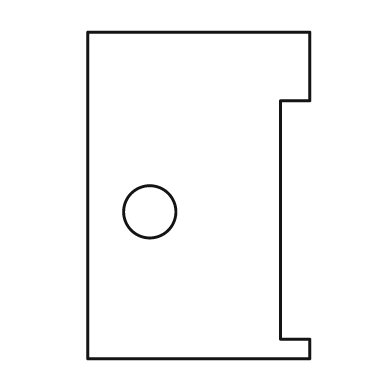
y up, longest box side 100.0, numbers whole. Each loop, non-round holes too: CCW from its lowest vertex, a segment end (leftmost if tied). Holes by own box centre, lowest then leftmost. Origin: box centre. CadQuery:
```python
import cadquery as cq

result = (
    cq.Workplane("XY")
    .moveTo(-34.0, -50.0)
    .lineTo(34.0, -50.0)
    .lineTo(34.0, -44.0)
    .lineTo(25.0, -44.0)
    .lineTo(25.0, 29.0)
    .lineTo(34.0, 29.0)
    .lineTo(34.0, 50.0)
    .lineTo(-34.0, 50.0)
    .close()
    .moveTo(-15.0, -5.0)
    .circle(8.0)
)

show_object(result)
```